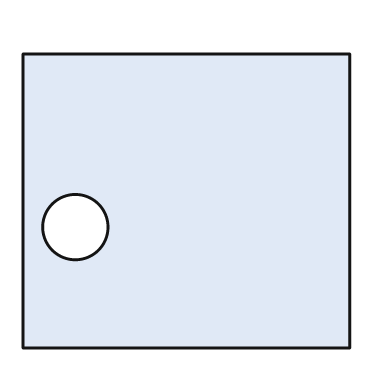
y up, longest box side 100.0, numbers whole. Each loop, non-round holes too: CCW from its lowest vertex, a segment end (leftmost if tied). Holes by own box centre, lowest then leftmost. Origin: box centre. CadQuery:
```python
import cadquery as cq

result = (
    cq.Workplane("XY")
    .moveTo(-50.0, -45.0)
    .lineTo(50.0, -45.0)
    .lineTo(50.0, 45.0)
    .lineTo(-50.0, 45.0)
    .close()
    .moveTo(-34.0, -8.0)
    .circle(10.0)
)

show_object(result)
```